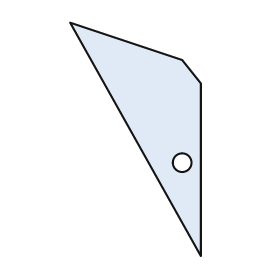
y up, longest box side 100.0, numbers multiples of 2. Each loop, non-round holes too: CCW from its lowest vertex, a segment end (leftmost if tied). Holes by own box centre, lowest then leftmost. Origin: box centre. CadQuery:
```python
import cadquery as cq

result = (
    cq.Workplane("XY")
    .moveTo(28.0, -50.0)
    .lineTo(28.0, 24.0)
    .lineTo(20.0, 34.0)
    .lineTo(-28.0, 50.0)
    .close()
    .moveTo(20.0, -10.0)
    .circle(4.0)
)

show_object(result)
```